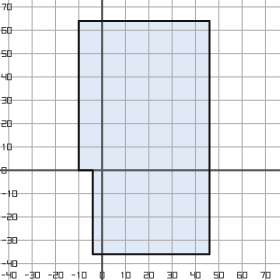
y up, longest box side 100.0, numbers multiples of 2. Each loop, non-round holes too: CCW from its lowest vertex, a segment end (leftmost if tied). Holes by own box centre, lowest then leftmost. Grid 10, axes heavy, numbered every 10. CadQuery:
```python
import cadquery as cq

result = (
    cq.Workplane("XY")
    .moveTo(-4.0, -36.0)
    .lineTo(46.0, -36.0)
    .lineTo(46.0, 64.0)
    .lineTo(-10.0, 64.0)
    .lineTo(-10.0, 0.0)
    .lineTo(-4.0, 0.0)
    .close()
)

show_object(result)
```